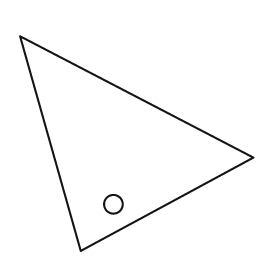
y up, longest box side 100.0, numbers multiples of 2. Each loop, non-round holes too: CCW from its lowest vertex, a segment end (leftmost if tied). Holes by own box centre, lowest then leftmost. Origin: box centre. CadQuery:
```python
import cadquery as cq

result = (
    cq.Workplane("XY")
    .moveTo(-24.0, -46.0)
    .lineTo(50.0, -6.0)
    .lineTo(-50.0, 46.0)
    .close()
    .moveTo(-10.0, -26.0)
    .circle(4.0)
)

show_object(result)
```